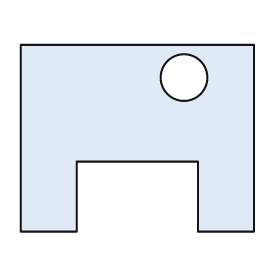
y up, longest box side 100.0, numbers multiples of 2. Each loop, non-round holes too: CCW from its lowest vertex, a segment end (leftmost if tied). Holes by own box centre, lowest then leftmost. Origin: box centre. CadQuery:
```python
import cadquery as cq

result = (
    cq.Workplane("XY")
    .moveTo(-50.0, -40.0)
    .lineTo(-26.0, -40.0)
    .lineTo(-26.0, -10.0)
    .lineTo(26.0, -10.0)
    .lineTo(26.0, -40.0)
    .lineTo(50.0, -40.0)
    .lineTo(50.0, 40.0)
    .lineTo(-50.0, 40.0)
    .close()
    .moveTo(20.0, 26.0)
    .circle(10.0)
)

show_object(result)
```